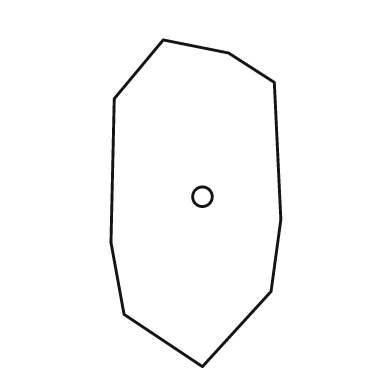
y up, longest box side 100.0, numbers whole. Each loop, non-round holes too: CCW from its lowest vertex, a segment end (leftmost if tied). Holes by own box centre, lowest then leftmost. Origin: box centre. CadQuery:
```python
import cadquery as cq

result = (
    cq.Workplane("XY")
    .moveTo(2.0, -50.0)
    .lineTo(23.0, -27.0)
    .lineTo(26.0, -5.0)
    .lineTo(24.0, 37.0)
    .lineTo(10.0, 46.0)
    .lineTo(-10.0, 50.0)
    .lineTo(-25.0, 32.0)
    .lineTo(-26.0, -12.0)
    .lineTo(-22.0, -34.0)
    .close()
    .moveTo(2.0, 2.0)
    .circle(3.0)
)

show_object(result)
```